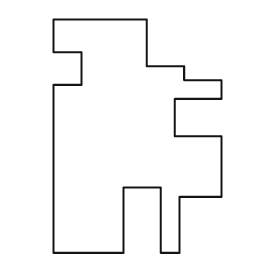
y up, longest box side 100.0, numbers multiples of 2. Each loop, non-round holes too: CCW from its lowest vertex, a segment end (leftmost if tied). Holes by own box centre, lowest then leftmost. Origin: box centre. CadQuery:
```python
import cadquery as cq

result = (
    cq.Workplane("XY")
    .moveTo(-36.0, -50.0)
    .lineTo(-6.0, -50.0)
    .lineTo(-6.0, -22.0)
    .lineTo(10.0, -22.0)
    .lineTo(10.0, -50.0)
    .lineTo(18.0, -50.0)
    .lineTo(18.0, -26.0)
    .lineTo(36.0, -26.0)
    .lineTo(36.0, 0.0)
    .lineTo(16.0, 0.0)
    .lineTo(16.0, 16.0)
    .lineTo(36.0, 16.0)
    .lineTo(36.0, 24.0)
    .lineTo(20.0, 24.0)
    .lineTo(20.0, 30.0)
    .lineTo(4.0, 30.0)
    .lineTo(4.0, 50.0)
    .lineTo(-36.0, 50.0)
    .lineTo(-36.0, 36.0)
    .lineTo(-24.0, 36.0)
    .lineTo(-24.0, 22.0)
    .lineTo(-36.0, 22.0)
    .close()
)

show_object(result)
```